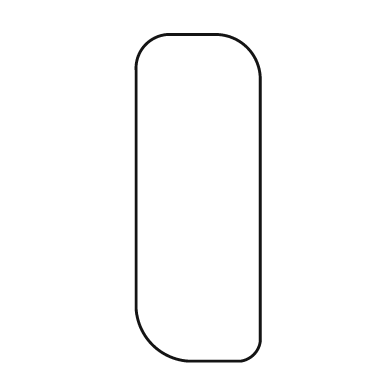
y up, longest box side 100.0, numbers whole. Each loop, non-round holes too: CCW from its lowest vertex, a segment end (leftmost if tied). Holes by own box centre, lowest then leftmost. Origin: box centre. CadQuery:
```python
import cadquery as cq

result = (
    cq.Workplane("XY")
    .moveTo(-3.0, -50.0)
    .lineTo(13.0, -50.0)
    .threePointArc((17.0, -48.0), (19.0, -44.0))
    .lineTo(19.0, 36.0)
    .threePointArc((15.0, 46.0), (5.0, 50.0))
    .lineTo(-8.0, 50.0)
    .threePointArc((-16.0, 47.0), (-19.0, 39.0))
    .lineTo(-19.0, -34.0)
    .threePointArc((-14.0, -45.0), (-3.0, -50.0))
    .close()
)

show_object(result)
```